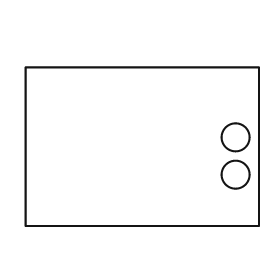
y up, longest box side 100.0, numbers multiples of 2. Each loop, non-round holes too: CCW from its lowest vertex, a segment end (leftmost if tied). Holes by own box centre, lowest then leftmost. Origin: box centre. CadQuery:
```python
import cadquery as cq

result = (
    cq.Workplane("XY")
    .moveTo(-50.0, -34.0)
    .lineTo(50.0, -34.0)
    .lineTo(50.0, 34.0)
    .lineTo(-50.0, 34.0)
    .close()
    .moveTo(40.0, -12.0)
    .circle(6.0)
    .moveTo(40.0, 4.0)
    .circle(6.0)
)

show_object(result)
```